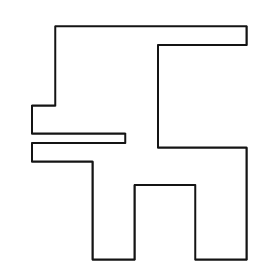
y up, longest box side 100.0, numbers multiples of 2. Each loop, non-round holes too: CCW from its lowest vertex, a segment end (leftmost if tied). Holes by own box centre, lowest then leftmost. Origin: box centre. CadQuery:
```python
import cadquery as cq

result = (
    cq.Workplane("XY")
    .moveTo(-20.0, -50.0)
    .lineTo(-2.0, -50.0)
    .lineTo(-2.0, -18.0)
    .lineTo(24.0, -18.0)
    .lineTo(24.0, -50.0)
    .lineTo(46.0, -50.0)
    .lineTo(46.0, -2.0)
    .lineTo(8.0, -2.0)
    .lineTo(8.0, 42.0)
    .lineTo(46.0, 42.0)
    .lineTo(46.0, 50.0)
    .lineTo(-36.0, 50.0)
    .lineTo(-36.0, 16.0)
    .lineTo(-46.0, 16.0)
    .lineTo(-46.0, 4.0)
    .lineTo(-6.0, 4.0)
    .lineTo(-6.0, 0.0)
    .lineTo(-46.0, 0.0)
    .lineTo(-46.0, -8.0)
    .lineTo(-20.0, -8.0)
    .close()
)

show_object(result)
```